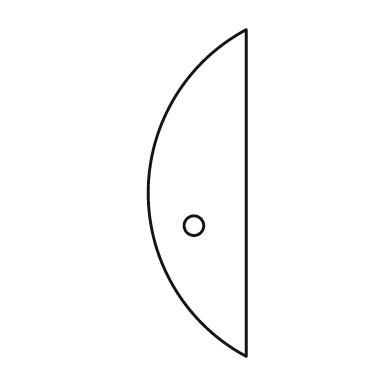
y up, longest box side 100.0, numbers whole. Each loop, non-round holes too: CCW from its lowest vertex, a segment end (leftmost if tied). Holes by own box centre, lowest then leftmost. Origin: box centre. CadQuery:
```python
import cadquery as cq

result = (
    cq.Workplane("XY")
    .moveTo(15.0, -50.0)
    .lineTo(15.0, 50.0)
    .threePointArc((-15.0, 0.0), (15.0, -50.0))
    .close()
    .moveTo(-1.0, -10.0)
    .circle(3.0)
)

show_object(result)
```